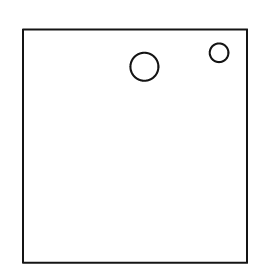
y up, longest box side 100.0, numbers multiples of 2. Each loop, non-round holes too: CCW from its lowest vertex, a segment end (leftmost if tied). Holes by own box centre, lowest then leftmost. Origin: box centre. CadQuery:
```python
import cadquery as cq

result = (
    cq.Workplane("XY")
    .moveTo(-48.0, -50.0)
    .lineTo(48.0, -50.0)
    .lineTo(48.0, 50.0)
    .lineTo(-48.0, 50.0)
    .close()
    .moveTo(4.0, 34.0)
    .circle(6.0)
    .moveTo(36.0, 40.0)
    .circle(4.0)
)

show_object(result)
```